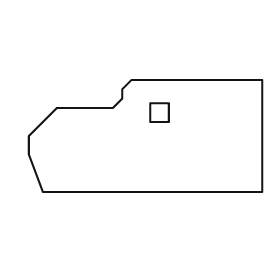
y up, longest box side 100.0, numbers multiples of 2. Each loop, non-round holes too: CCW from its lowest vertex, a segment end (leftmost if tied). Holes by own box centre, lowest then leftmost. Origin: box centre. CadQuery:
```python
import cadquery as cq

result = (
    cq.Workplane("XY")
    .moveTo(-44.0, -24.0)
    .lineTo(50.0, -24.0)
    .lineTo(50.0, 24.0)
    .lineTo(-6.0, 24.0)
    .lineTo(-10.0, 20.0)
    .lineTo(-10.0, 16.0)
    .lineTo(-14.0, 12.0)
    .lineTo(-38.0, 12.0)
    .lineTo(-50.0, 0.0)
    .lineTo(-50.0, -8.0)
    .close()
    .moveTo(2.0, 6.0)
    .lineTo(10.0, 6.0)
    .lineTo(10.0, 14.0)
    .lineTo(2.0, 14.0)
    .close()
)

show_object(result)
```